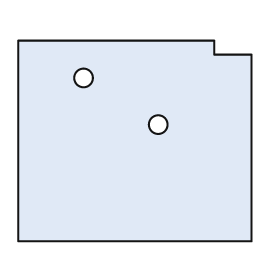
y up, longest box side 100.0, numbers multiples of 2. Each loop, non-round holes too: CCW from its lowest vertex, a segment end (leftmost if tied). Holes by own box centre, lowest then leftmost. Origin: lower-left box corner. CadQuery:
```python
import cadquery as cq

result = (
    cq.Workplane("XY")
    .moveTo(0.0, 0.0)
    .lineTo(100.0, 0.0)
    .lineTo(100.0, 80.0)
    .lineTo(84.0, 80.0)
    .lineTo(84.0, 86.0)
    .lineTo(0.0, 86.0)
    .close()
    .moveTo(60.0, 50.0)
    .circle(4.0)
    .moveTo(28.0, 70.0)
    .circle(4.0)
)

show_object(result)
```